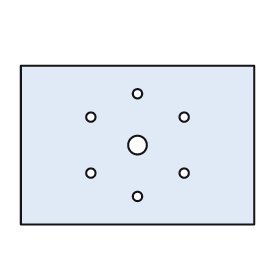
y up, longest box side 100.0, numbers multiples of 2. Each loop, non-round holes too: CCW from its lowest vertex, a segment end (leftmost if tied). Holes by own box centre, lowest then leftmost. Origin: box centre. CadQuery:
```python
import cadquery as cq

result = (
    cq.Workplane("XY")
    .moveTo(-50.0, -34.0)
    .lineTo(50.0, -34.0)
    .lineTo(50.0, 34.0)
    .lineTo(-50.0, 34.0)
    .close()
    .moveTo(0.0, -22.0)
    .circle(2.0)
    .moveTo(-20.0, -12.0)
    .circle(2.0)
    .moveTo(20.0, -12.0)
    .circle(2.0)
    .moveTo(0.0, 0.0)
    .circle(4.0)
    .moveTo(-20.0, 12.0)
    .circle(2.0)
    .moveTo(20.0, 12.0)
    .circle(2.0)
    .moveTo(0.0, 22.0)
    .circle(2.0)
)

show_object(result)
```